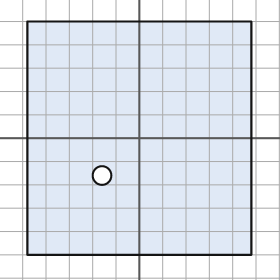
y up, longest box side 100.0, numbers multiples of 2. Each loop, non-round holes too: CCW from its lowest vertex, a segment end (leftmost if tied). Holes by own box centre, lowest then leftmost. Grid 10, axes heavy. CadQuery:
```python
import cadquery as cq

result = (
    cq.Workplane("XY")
    .moveTo(-48.0, -50.0)
    .lineTo(48.0, -50.0)
    .lineTo(48.0, 50.0)
    .lineTo(-48.0, 50.0)
    .close()
    .moveTo(-16.0, -16.0)
    .circle(4.0)
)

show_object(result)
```